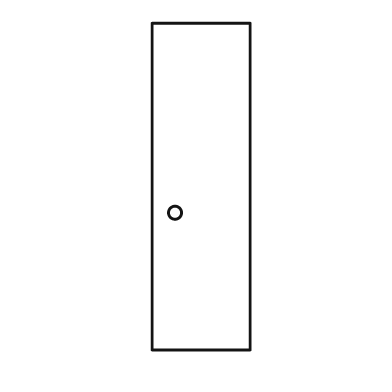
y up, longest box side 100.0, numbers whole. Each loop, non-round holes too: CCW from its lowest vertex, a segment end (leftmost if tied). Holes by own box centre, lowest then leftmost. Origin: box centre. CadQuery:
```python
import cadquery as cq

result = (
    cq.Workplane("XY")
    .moveTo(-15.0, -50.0)
    .lineTo(15.0, -50.0)
    .lineTo(15.0, 50.0)
    .lineTo(-15.0, 50.0)
    .close()
    .moveTo(-8.0, -8.0)
    .circle(2.0)
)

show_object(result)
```